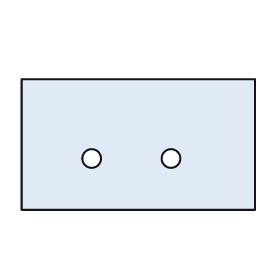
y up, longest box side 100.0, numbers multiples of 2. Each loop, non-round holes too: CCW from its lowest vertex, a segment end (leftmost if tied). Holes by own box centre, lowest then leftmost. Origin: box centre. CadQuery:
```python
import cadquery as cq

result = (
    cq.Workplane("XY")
    .moveTo(-50.0, -28.0)
    .lineTo(50.0, -28.0)
    .lineTo(50.0, 28.0)
    .lineTo(-50.0, 28.0)
    .close()
    .moveTo(-20.0, -6.0)
    .circle(4.0)
    .moveTo(14.0, -6.0)
    .circle(4.0)
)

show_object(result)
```